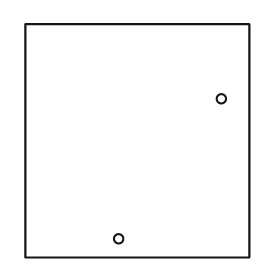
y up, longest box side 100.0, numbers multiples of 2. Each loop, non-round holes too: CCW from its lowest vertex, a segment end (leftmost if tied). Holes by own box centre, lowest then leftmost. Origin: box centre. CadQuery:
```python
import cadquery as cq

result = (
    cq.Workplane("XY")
    .moveTo(-48.0, -50.0)
    .lineTo(48.0, -50.0)
    .lineTo(48.0, 50.0)
    .lineTo(-48.0, 50.0)
    .close()
    .moveTo(-8.0, -42.0)
    .circle(2.0)
    .moveTo(36.0, 18.0)
    .circle(2.0)
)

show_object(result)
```